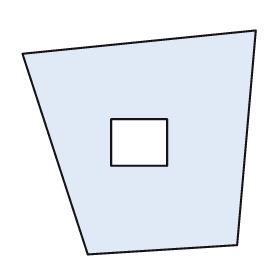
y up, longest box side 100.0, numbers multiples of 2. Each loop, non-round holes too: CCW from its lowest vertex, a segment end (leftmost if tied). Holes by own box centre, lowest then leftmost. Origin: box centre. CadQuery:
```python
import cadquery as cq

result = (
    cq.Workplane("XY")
    .moveTo(-22.0, -48.0)
    .lineTo(42.0, -44.0)
    .lineTo(50.0, 48.0)
    .lineTo(-50.0, 38.0)
    .close()
    .moveTo(-12.0, -10.0)
    .lineTo(12.0, -10.0)
    .lineTo(12.0, 10.0)
    .lineTo(-12.0, 10.0)
    .close()
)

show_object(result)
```